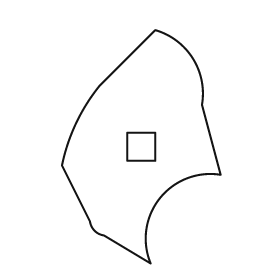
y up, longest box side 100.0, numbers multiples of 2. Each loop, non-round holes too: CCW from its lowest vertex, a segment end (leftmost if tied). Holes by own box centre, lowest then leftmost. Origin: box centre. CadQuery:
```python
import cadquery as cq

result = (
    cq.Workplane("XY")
    .moveTo(4.0, -50.0)
    .threePointArc((8.0, -22.0), (34.0, -12.0))
    .lineTo(26.0, 18.0)
    .threePointArc((22.0, 38.0), (6.0, 50.0))
    .lineTo(-18.0, 26.0)
    .threePointArc((-28.0, 10.0), (-34.0, -8.0))
    .lineTo(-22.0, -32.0)
    .threePointArc((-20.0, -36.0), (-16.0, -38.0))
    .close()
    .moveTo(-6.0, -6.0)
    .lineTo(6.0, -6.0)
    .lineTo(6.0, 6.0)
    .lineTo(-6.0, 6.0)
    .close()
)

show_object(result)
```